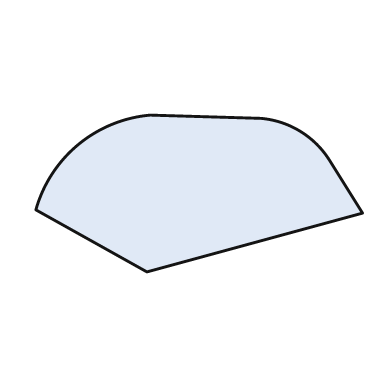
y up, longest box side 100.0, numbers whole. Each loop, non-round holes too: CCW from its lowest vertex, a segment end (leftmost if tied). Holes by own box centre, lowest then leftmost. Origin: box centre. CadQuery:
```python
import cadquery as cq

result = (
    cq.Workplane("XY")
    .moveTo(-16.0, -24.0)
    .lineTo(50.0, -6.0)
    .lineTo(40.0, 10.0)
    .threePointArc((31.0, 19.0), (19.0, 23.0))
    .lineTo(-15.0, 24.0)
    .threePointArc((-37.0, 15.0), (-50.0, -5.0))
    .close()
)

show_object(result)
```